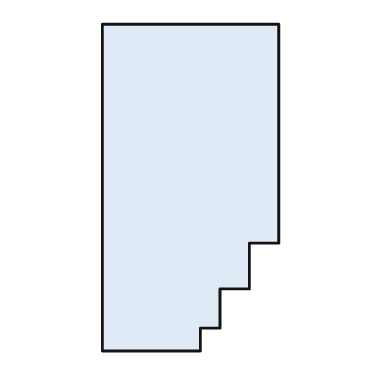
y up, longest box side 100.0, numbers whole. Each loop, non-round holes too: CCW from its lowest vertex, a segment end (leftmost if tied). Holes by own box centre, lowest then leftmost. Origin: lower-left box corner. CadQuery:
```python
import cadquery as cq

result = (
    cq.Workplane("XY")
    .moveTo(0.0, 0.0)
    .lineTo(30.0, 0.0)
    .lineTo(30.0, 7.0)
    .lineTo(36.0, 7.0)
    .lineTo(36.0, 19.0)
    .lineTo(45.0, 19.0)
    .lineTo(45.0, 33.0)
    .lineTo(54.0, 33.0)
    .lineTo(54.0, 100.0)
    .lineTo(0.0, 100.0)
    .close()
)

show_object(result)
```